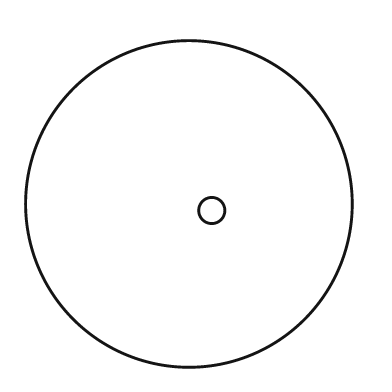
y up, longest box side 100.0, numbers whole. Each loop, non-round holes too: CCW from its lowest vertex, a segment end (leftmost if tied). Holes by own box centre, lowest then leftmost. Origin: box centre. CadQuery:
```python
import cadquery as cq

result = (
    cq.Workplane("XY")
    .moveTo(0.0, 0.0)
    .circle(50.0)
    .moveTo(7.0, -2.0)
    .circle(4.0)
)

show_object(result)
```